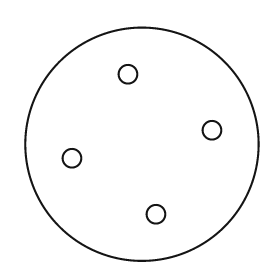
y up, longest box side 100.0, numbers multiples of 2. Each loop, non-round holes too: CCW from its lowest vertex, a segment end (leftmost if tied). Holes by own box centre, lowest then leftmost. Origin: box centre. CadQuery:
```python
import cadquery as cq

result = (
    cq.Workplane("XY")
    .moveTo(0.0, 0.0)
    .circle(50.0)
    .moveTo(6.0, -30.0)
    .circle(4.0)
    .moveTo(-30.0, -6.0)
    .circle(4.0)
    .moveTo(30.0, 6.0)
    .circle(4.0)
    .moveTo(-6.0, 30.0)
    .circle(4.0)
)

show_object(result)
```